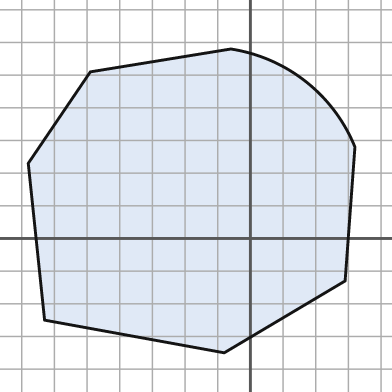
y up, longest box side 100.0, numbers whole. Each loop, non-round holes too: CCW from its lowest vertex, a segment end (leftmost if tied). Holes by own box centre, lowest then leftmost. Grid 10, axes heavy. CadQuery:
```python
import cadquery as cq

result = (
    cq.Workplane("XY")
    .moveTo(-8.0, -35.0)
    .lineTo(29.0, -13.0)
    .lineTo(32.0, 28.0)
    .threePointArc((17.0, 48.0), (-6.0, 58.0))
    .lineTo(-49.0, 51.0)
    .lineTo(-68.0, 23.0)
    .lineTo(-63.0, -25.0)
    .close()
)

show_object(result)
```